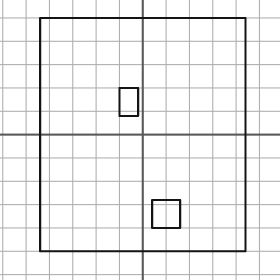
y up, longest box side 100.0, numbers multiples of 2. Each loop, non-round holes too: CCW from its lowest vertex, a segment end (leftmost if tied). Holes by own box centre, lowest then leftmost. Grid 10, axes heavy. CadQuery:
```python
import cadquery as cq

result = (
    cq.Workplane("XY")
    .moveTo(-44.0, -50.0)
    .lineTo(44.0, -50.0)
    .lineTo(44.0, 50.0)
    .lineTo(-44.0, 50.0)
    .close()
    .moveTo(4.0, -40.0)
    .lineTo(16.0, -40.0)
    .lineTo(16.0, -28.0)
    .lineTo(4.0, -28.0)
    .close()
    .moveTo(-10.0, 8.0)
    .lineTo(-2.0, 8.0)
    .lineTo(-2.0, 20.0)
    .lineTo(-10.0, 20.0)
    .close()
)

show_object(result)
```